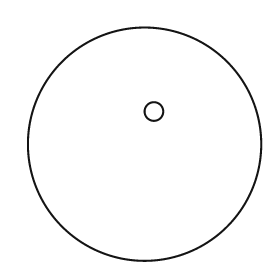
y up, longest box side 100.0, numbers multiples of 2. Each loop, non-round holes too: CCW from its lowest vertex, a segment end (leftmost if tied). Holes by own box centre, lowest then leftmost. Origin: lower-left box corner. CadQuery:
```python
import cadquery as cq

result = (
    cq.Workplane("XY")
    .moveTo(50.0, 50.0)
    .circle(50.0)
    .moveTo(54.0, 64.0)
    .circle(4.0)
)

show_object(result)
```